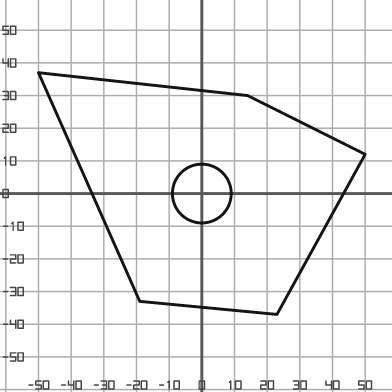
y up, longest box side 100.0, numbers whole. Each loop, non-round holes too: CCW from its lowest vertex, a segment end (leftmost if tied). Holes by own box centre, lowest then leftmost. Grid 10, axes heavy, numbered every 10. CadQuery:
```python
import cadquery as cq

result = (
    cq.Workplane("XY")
    .moveTo(23.0, -37.0)
    .lineTo(50.0, 12.0)
    .lineTo(14.0, 30.0)
    .lineTo(-50.0, 37.0)
    .lineTo(-19.0, -33.0)
    .close()
    .moveTo(0.0, 0.0)
    .circle(9.0)
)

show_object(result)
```